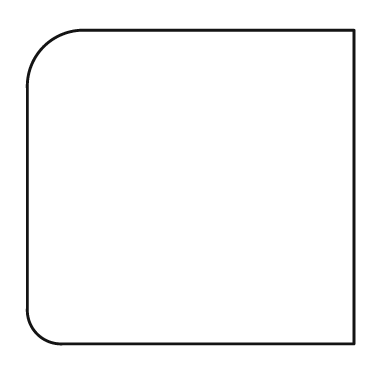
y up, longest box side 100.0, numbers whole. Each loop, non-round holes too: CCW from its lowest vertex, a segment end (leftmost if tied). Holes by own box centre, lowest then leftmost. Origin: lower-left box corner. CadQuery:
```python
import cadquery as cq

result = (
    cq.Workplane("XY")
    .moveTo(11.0, 0.0)
    .lineTo(100.0, 0.0)
    .lineTo(100.0, 96.0)
    .lineTo(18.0, 96.0)
    .threePointArc((5.0, 91.0), (0.0, 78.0))
    .lineTo(0.0, 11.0)
    .threePointArc((3.0, 3.0), (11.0, 0.0))
    .close()
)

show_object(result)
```